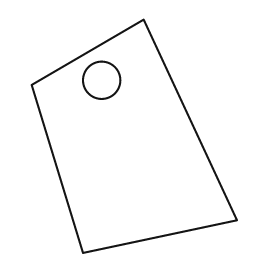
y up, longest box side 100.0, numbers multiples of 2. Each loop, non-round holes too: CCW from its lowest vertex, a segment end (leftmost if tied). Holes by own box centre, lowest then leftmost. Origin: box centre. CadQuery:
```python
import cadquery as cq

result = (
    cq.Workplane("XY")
    .moveTo(-22.0, -50.0)
    .lineTo(44.0, -36.0)
    .lineTo(4.0, 50.0)
    .lineTo(-44.0, 22.0)
    .close()
    .moveTo(-14.0, 24.0)
    .circle(8.0)
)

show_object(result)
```